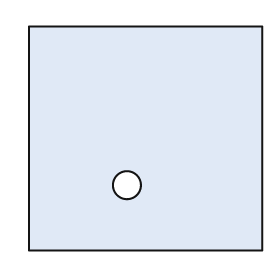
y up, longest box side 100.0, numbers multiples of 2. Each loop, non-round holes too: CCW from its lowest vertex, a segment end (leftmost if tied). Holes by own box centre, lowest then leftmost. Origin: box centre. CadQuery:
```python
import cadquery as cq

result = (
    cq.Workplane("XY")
    .moveTo(-50.0, -48.0)
    .lineTo(50.0, -48.0)
    .lineTo(50.0, 48.0)
    .lineTo(-50.0, 48.0)
    .close()
    .moveTo(-8.0, -20.0)
    .circle(6.0)
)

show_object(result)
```